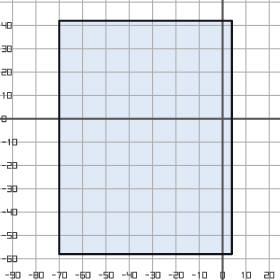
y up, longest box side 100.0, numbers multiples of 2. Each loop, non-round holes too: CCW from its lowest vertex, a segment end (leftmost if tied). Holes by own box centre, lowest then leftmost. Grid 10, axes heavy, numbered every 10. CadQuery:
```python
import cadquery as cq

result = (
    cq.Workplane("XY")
    .moveTo(-70.0, -58.0)
    .lineTo(4.0, -58.0)
    .lineTo(4.0, 42.0)
    .lineTo(-70.0, 42.0)
    .close()
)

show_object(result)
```